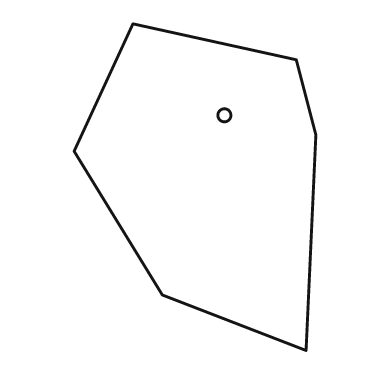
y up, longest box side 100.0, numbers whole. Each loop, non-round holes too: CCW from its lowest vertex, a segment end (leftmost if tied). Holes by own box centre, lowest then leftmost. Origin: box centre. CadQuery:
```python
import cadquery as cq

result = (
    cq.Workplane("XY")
    .moveTo(34.0, -50.0)
    .lineTo(37.0, 16.0)
    .lineTo(31.0, 39.0)
    .lineTo(-19.0, 50.0)
    .lineTo(-37.0, 11.0)
    .lineTo(-10.0, -33.0)
    .close()
    .moveTo(9.0, 22.0)
    .circle(2.0)
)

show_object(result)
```